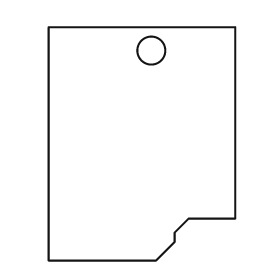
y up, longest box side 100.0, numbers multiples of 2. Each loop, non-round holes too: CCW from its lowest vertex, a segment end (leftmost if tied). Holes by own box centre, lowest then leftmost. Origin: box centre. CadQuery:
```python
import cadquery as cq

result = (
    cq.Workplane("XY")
    .moveTo(-40.0, -50.0)
    .lineTo(6.0, -50.0)
    .lineTo(14.0, -42.0)
    .lineTo(14.0, -38.0)
    .lineTo(20.0, -32.0)
    .lineTo(40.0, -32.0)
    .lineTo(40.0, 50.0)
    .lineTo(-40.0, 50.0)
    .close()
    .moveTo(4.0, 40.0)
    .circle(6.0)
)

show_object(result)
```